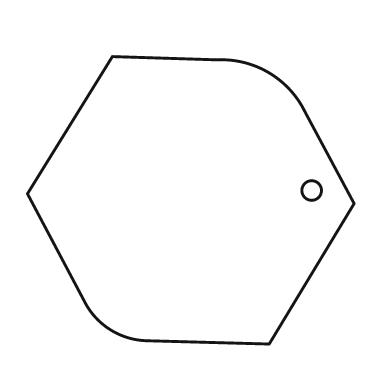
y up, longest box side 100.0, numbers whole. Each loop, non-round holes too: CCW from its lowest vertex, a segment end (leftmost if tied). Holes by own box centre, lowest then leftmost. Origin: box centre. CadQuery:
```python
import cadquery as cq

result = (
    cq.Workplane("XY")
    .moveTo(24.0, -44.0)
    .lineTo(50.0, -1.0)
    .lineTo(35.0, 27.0)
    .threePointArc((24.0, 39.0), (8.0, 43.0))
    .lineTo(-24.0, 44.0)
    .lineTo(-50.0, 2.0)
    .lineTo(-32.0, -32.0)
    .threePointArc((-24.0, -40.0), (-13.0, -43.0))
    .close()
    .moveTo(37.0, 3.0)
    .circle(3.0)
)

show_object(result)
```